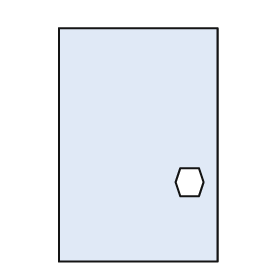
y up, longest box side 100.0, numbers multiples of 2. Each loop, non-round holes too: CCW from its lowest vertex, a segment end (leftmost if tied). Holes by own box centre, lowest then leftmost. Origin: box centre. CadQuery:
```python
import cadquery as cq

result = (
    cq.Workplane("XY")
    .moveTo(-34.0, -50.0)
    .lineTo(34.0, -50.0)
    .lineTo(34.0, 50.0)
    .lineTo(-34.0, 50.0)
    .close()
    .moveTo(18.0, -22.0)
    .lineTo(26.0, -22.0)
    .lineTo(28.0, -16.0)
    .lineTo(26.0, -10.0)
    .lineTo(18.0, -10.0)
    .lineTo(16.0, -16.0)
    .close()
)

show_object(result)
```